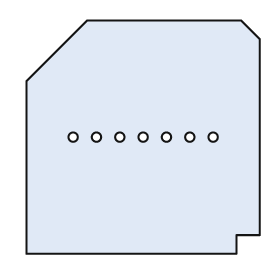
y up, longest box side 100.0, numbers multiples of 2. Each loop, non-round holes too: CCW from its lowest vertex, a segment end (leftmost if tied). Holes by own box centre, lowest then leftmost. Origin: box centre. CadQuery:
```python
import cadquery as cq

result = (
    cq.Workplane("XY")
    .moveTo(-50.0, -50.0)
    .lineTo(40.0, -50.0)
    .lineTo(40.0, -42.0)
    .lineTo(50.0, -42.0)
    .lineTo(50.0, 42.0)
    .lineTo(42.0, 50.0)
    .lineTo(-24.0, 50.0)
    .lineTo(-50.0, 24.0)
    .close()
    .moveTo(-30.0, 0.0)
    .circle(2.0)
    .moveTo(-20.0, 0.0)
    .circle(2.0)
    .moveTo(-10.0, 0.0)
    .circle(2.0)
    .moveTo(0.0, 0.0)
    .circle(2.0)
    .moveTo(10.0, 0.0)
    .circle(2.0)
    .moveTo(20.0, 0.0)
    .circle(2.0)
    .moveTo(30.0, 0.0)
    .circle(2.0)
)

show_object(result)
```